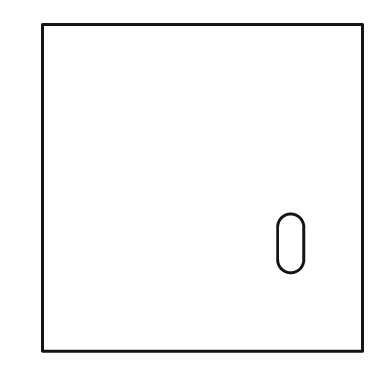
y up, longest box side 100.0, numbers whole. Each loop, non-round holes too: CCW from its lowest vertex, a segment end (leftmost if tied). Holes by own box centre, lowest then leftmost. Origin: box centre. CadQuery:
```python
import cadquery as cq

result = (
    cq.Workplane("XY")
    .moveTo(-49.0, -50.0)
    .lineTo(49.0, -50.0)
    .lineTo(49.0, 50.0)
    .lineTo(-49.0, 50.0)
    .close()
    .moveTo(23.0, -22.0)
    .threePointArc((27.0, -26.0), (31.0, -22.0))
    .lineTo(31.0, -12.0)
    .threePointArc((27.0, -8.0), (23.0, -12.0))
    .close()
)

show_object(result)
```